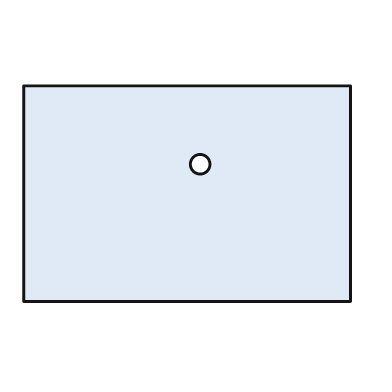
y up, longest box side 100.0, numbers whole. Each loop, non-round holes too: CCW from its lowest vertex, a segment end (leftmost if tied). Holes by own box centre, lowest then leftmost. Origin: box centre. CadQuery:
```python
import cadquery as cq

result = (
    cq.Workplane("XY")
    .moveTo(-50.0, -33.0)
    .lineTo(50.0, -33.0)
    .lineTo(50.0, 33.0)
    .lineTo(-50.0, 33.0)
    .close()
    .moveTo(4.0, 9.0)
    .circle(3.0)
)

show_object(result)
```